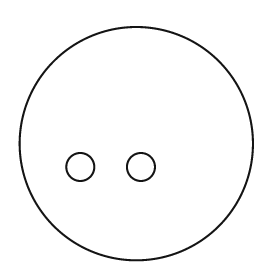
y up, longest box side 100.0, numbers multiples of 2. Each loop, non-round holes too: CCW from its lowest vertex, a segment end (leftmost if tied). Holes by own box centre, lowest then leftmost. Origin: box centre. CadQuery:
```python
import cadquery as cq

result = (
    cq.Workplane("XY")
    .moveTo(0.0, 0.0)
    .circle(50.0)
    .moveTo(-24.0, -10.0)
    .circle(6.0)
    .moveTo(2.0, -10.0)
    .circle(6.0)
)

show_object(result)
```